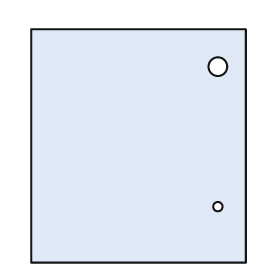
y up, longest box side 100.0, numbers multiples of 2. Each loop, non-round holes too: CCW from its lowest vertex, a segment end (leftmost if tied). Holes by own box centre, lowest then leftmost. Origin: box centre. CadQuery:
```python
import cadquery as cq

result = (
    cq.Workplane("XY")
    .moveTo(-46.0, -50.0)
    .lineTo(46.0, -50.0)
    .lineTo(46.0, 50.0)
    .lineTo(-46.0, 50.0)
    .close()
    .moveTo(34.0, -26.0)
    .circle(2.0)
    .moveTo(34.0, 34.0)
    .circle(4.0)
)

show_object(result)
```